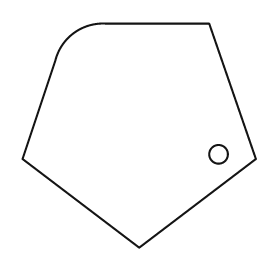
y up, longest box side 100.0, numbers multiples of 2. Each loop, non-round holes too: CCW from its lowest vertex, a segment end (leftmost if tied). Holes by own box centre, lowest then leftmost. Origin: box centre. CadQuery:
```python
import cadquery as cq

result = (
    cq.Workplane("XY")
    .moveTo(0.0, -48.0)
    .lineTo(50.0, -10.0)
    .lineTo(30.0, 48.0)
    .lineTo(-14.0, 48.0)
    .threePointArc((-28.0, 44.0), (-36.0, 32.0))
    .lineTo(-50.0, -10.0)
    .close()
    .moveTo(34.0, -8.0)
    .circle(4.0)
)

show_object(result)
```